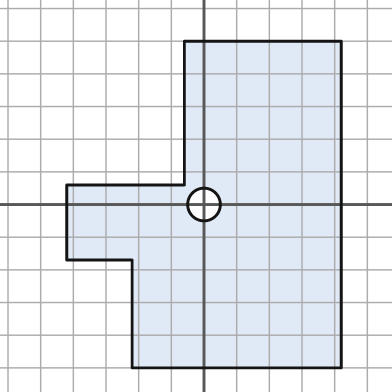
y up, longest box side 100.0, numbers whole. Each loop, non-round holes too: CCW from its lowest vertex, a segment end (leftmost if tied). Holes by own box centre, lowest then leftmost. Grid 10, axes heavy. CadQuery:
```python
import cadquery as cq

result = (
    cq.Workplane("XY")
    .moveTo(-22.0, -50.0)
    .lineTo(42.0, -50.0)
    .lineTo(42.0, 50.0)
    .lineTo(-6.0, 50.0)
    .lineTo(-6.0, 6.0)
    .lineTo(-42.0, 6.0)
    .lineTo(-42.0, -17.0)
    .lineTo(-22.0, -17.0)
    .close()
    .moveTo(0.0, 0.0)
    .circle(5.0)
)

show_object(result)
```